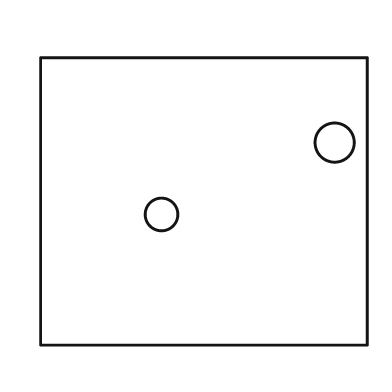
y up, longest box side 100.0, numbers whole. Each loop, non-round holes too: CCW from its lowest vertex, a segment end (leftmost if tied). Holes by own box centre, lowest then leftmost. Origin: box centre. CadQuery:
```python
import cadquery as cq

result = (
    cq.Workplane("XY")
    .moveTo(-50.0, -44.0)
    .lineTo(50.0, -44.0)
    .lineTo(50.0, 44.0)
    .lineTo(-50.0, 44.0)
    .close()
    .moveTo(-13.0, -4.0)
    .circle(5.0)
    .moveTo(40.0, 18.0)
    .circle(6.0)
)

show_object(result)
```